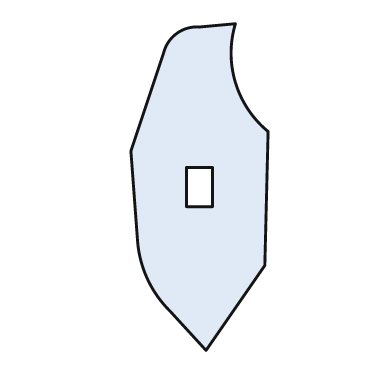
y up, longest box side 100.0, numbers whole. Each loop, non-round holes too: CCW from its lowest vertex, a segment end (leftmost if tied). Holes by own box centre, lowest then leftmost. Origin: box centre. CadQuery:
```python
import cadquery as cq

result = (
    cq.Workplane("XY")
    .moveTo(2.0, -50.0)
    .lineTo(20.0, -24.0)
    .lineTo(21.0, 17.0)
    .threePointArc((11.0, 32.0), (11.0, 50.0))
    .lineTo(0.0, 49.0)
    .threePointArc((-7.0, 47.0), (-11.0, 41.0))
    .lineTo(-21.0, 11.0)
    .lineTo(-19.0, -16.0)
    .threePointArc((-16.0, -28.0), (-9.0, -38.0))
    .close()
    .moveTo(-4.0, -6.0)
    .lineTo(4.0, -6.0)
    .lineTo(4.0, 6.0)
    .lineTo(-4.0, 6.0)
    .close()
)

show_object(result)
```